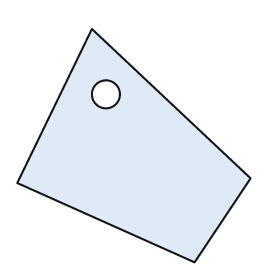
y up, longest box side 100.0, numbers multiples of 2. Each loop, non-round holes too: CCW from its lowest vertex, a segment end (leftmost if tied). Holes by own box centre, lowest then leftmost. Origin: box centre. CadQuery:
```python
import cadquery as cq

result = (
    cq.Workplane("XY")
    .moveTo(26.0, -50.0)
    .lineTo(50.0, -14.0)
    .lineTo(-18.0, 50.0)
    .lineTo(-50.0, -16.0)
    .close()
    .moveTo(-12.0, 22.0)
    .circle(6.0)
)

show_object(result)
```